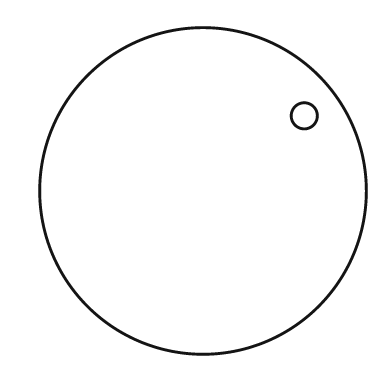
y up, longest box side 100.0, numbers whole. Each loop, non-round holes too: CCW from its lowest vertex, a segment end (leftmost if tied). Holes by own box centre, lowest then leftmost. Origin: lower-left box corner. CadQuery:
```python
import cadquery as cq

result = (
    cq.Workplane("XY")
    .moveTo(50.0, 50.0)
    .circle(50.0)
    .moveTo(81.0, 73.0)
    .circle(4.0)
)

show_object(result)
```